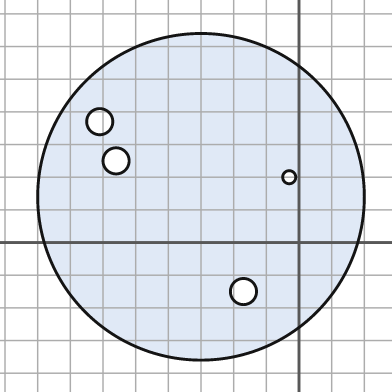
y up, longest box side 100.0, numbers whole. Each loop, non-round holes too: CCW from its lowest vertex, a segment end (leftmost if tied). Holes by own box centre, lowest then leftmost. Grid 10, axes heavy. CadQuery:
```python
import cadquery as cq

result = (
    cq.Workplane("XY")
    .moveTo(-30.0, 14.0)
    .circle(50.0)
    .moveTo(-17.0, -15.0)
    .circle(4.0)
    .moveTo(-3.0, 20.0)
    .circle(2.0)
    .moveTo(-56.0, 25.0)
    .circle(4.0)
    .moveTo(-61.0, 37.0)
    .circle(4.0)
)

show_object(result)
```